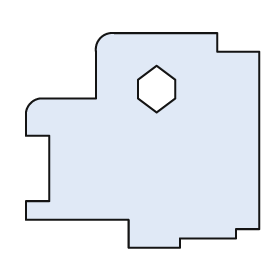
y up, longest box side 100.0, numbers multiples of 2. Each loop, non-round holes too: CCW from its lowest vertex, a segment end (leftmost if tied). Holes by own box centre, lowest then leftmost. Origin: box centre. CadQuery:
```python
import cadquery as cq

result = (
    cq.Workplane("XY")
    .moveTo(-6.0, -46.0)
    .lineTo(16.0, -46.0)
    .lineTo(16.0, -42.0)
    .lineTo(40.0, -42.0)
    .lineTo(40.0, -38.0)
    .lineTo(50.0, -38.0)
    .lineTo(50.0, 38.0)
    .lineTo(32.0, 38.0)
    .lineTo(32.0, 46.0)
    .lineTo(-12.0, 46.0)
    .threePointArc((-18.0, 44.0), (-20.0, 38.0))
    .lineTo(-20.0, 18.0)
    .lineTo(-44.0, 18.0)
    .threePointArc((-48.0, 16.0), (-50.0, 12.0))
    .lineTo(-50.0, 2.0)
    .lineTo(-40.0, 2.0)
    .lineTo(-40.0, -26.0)
    .lineTo(-50.0, -26.0)
    .lineTo(-50.0, -34.0)
    .lineTo(-6.0, -34.0)
    .close()
    .moveTo(6.0, 12.0)
    .lineTo(14.0, 18.0)
    .lineTo(14.0, 26.0)
    .lineTo(6.0, 32.0)
    .lineTo(-2.0, 26.0)
    .lineTo(-2.0, 18.0)
    .close()
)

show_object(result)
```